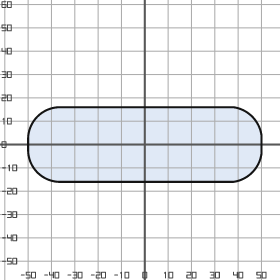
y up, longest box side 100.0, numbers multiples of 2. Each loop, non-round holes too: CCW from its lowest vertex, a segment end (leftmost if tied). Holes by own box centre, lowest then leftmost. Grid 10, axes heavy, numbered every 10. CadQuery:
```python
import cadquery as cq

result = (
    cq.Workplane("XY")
    .moveTo(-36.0, -16.0)
    .lineTo(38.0, -16.0)
    .threePointArc((46.0, -12.0), (50.0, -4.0))
    .lineTo(50.0, 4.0)
    .threePointArc((46.0, 12.0), (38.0, 16.0))
    .lineTo(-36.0, 16.0)
    .threePointArc((-46.0, 12.0), (-50.0, 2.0))
    .lineTo(-50.0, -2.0)
    .threePointArc((-46.0, -12.0), (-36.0, -16.0))
    .close()
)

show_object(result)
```